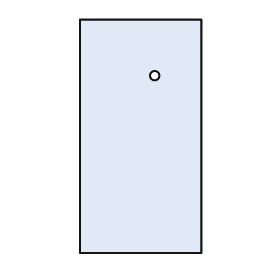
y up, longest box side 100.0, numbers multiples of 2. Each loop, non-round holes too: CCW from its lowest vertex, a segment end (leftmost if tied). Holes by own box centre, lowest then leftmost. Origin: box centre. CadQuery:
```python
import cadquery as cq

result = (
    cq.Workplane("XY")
    .moveTo(-26.0, -50.0)
    .lineTo(26.0, -50.0)
    .lineTo(26.0, 50.0)
    .lineTo(-26.0, 50.0)
    .close()
    .moveTo(6.0, 26.0)
    .circle(2.0)
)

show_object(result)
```